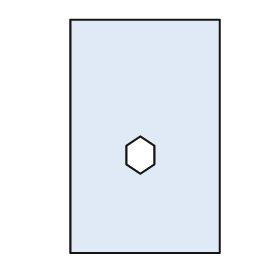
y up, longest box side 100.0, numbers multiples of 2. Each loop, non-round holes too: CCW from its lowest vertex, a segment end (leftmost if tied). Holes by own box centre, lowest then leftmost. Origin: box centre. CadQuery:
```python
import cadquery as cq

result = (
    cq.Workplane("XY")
    .moveTo(-32.0, -50.0)
    .lineTo(32.0, -50.0)
    .lineTo(32.0, 50.0)
    .lineTo(-32.0, 50.0)
    .close()
    .moveTo(-2.0, -16.0)
    .lineTo(4.0, -12.0)
    .lineTo(4.0, -4.0)
    .lineTo(-2.0, 0.0)
    .lineTo(-8.0, -4.0)
    .lineTo(-8.0, -12.0)
    .close()
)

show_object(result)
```